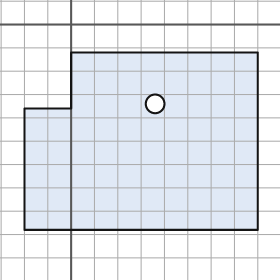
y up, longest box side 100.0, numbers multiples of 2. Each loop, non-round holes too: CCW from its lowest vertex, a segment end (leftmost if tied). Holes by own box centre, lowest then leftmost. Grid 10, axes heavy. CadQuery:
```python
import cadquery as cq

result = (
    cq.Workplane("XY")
    .moveTo(-20.0, -88.0)
    .lineTo(80.0, -88.0)
    .lineTo(80.0, -12.0)
    .lineTo(0.0, -12.0)
    .lineTo(0.0, -36.0)
    .lineTo(-20.0, -36.0)
    .close()
    .moveTo(36.0, -34.0)
    .circle(4.0)
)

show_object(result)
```